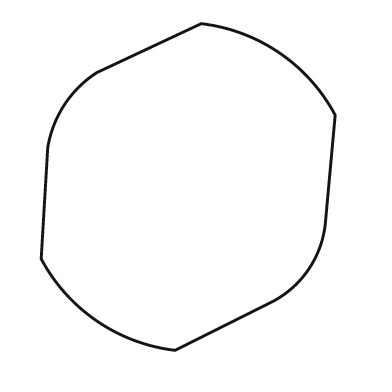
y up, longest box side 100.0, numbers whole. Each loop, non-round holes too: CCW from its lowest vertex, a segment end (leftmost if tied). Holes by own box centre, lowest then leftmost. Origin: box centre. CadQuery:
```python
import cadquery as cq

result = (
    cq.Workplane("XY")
    .moveTo(-4.0, -50.0)
    .lineTo(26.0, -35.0)
    .threePointArc((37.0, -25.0), (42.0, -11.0))
    .lineTo(45.0, 22.0)
    .threePointArc((28.0, 41.0), (4.0, 50.0))
    .lineTo(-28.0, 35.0)
    .threePointArc((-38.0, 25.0), (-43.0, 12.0))
    .lineTo(-45.0, -22.0)
    .threePointArc((-28.0, -41.0), (-4.0, -50.0))
    .close()
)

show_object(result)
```